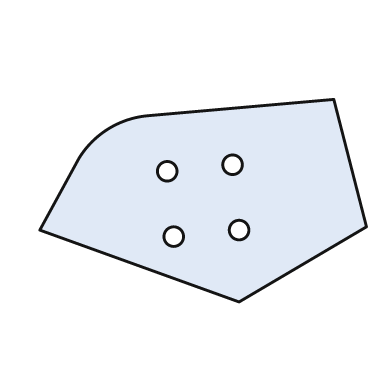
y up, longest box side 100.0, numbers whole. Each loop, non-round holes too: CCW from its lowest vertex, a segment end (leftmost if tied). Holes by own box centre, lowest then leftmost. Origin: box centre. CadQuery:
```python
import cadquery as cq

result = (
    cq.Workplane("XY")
    .moveTo(11.0, -31.0)
    .lineTo(50.0, -8.0)
    .lineTo(40.0, 31.0)
    .lineTo(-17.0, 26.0)
    .threePointArc((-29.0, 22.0), (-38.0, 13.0))
    .lineTo(-50.0, -9.0)
    .close()
    .moveTo(-9.0, -11.0)
    .circle(3.0)
    .moveTo(11.0, -9.0)
    .circle(3.0)
    .moveTo(-11.0, 9.0)
    .circle(3.0)
    .moveTo(9.0, 11.0)
    .circle(3.0)
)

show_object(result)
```